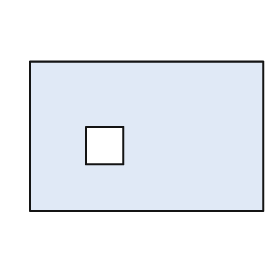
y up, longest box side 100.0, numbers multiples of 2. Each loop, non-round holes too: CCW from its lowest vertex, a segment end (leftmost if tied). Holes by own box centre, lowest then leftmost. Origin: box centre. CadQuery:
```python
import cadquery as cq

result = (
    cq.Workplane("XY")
    .moveTo(-50.0, -32.0)
    .lineTo(50.0, -32.0)
    .lineTo(50.0, 32.0)
    .lineTo(-50.0, 32.0)
    .close()
    .moveTo(-26.0, -12.0)
    .lineTo(-10.0, -12.0)
    .lineTo(-10.0, 4.0)
    .lineTo(-26.0, 4.0)
    .close()
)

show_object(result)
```